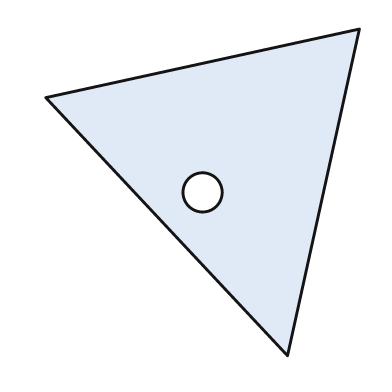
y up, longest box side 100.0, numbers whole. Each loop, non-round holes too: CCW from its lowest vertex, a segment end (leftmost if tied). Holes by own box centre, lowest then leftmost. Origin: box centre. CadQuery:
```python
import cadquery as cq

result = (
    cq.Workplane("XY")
    .moveTo(26.0, -50.0)
    .lineTo(48.0, 50.0)
    .lineTo(-48.0, 29.0)
    .close()
    .moveTo(0.0, 0.0)
    .circle(6.0)
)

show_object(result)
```